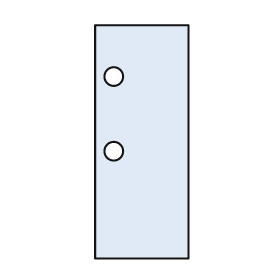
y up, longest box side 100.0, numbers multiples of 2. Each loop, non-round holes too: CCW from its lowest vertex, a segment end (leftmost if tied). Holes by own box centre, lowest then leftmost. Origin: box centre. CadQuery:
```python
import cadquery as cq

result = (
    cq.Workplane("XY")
    .moveTo(-20.0, -50.0)
    .lineTo(20.0, -50.0)
    .lineTo(20.0, 50.0)
    .lineTo(-20.0, 50.0)
    .close()
    .moveTo(-12.0, -4.0)
    .circle(4.0)
    .moveTo(-12.0, 28.0)
    .circle(4.0)
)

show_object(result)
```